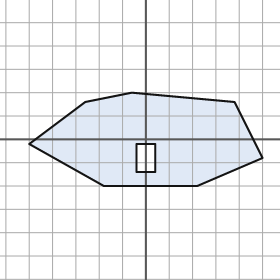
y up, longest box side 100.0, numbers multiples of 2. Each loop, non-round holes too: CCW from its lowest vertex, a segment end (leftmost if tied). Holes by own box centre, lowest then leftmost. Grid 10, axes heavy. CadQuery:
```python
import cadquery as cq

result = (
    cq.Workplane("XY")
    .moveTo(-18.0, -20.0)
    .lineTo(22.0, -20.0)
    .lineTo(50.0, -8.0)
    .lineTo(38.0, 16.0)
    .lineTo(-6.0, 20.0)
    .lineTo(-26.0, 16.0)
    .lineTo(-50.0, -2.0)
    .close()
    .moveTo(-4.0, -14.0)
    .lineTo(4.0, -14.0)
    .lineTo(4.0, -2.0)
    .lineTo(-4.0, -2.0)
    .close()
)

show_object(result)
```